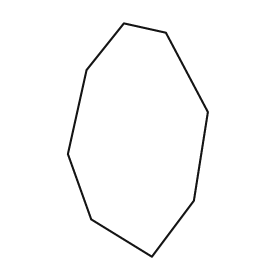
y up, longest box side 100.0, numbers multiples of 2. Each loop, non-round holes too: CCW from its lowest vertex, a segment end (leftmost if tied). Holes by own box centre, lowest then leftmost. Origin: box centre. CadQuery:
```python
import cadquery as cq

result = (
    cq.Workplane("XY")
    .moveTo(6.0, -50.0)
    .lineTo(24.0, -26.0)
    .lineTo(30.0, 12.0)
    .lineTo(12.0, 46.0)
    .lineTo(-6.0, 50.0)
    .lineTo(-22.0, 30.0)
    .lineTo(-30.0, -6.0)
    .lineTo(-20.0, -34.0)
    .close()
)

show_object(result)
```